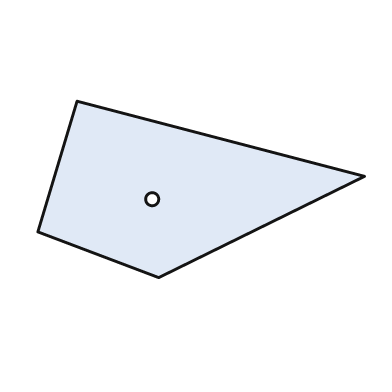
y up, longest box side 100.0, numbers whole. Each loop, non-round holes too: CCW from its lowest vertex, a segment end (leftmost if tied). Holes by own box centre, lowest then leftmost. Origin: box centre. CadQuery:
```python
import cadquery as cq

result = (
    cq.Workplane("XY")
    .moveTo(-13.0, -27.0)
    .lineTo(50.0, 4.0)
    .lineTo(-38.0, 27.0)
    .lineTo(-50.0, -13.0)
    .close()
    .moveTo(-15.0, -3.0)
    .circle(2.0)
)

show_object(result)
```